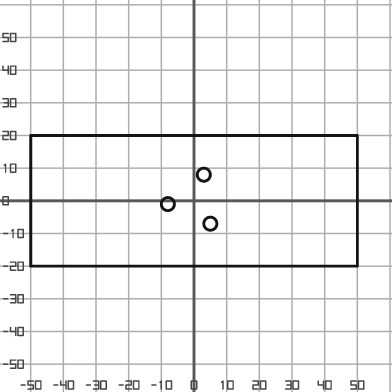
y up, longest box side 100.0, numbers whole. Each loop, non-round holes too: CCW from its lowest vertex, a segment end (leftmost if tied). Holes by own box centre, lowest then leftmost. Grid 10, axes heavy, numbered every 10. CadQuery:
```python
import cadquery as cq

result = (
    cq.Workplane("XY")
    .moveTo(-50.0, -20.0)
    .lineTo(50.0, -20.0)
    .lineTo(50.0, 20.0)
    .lineTo(-50.0, 20.0)
    .close()
    .moveTo(5.0, -7.0)
    .circle(2.0)
    .moveTo(-8.0, -1.0)
    .circle(2.0)
    .moveTo(3.0, 8.0)
    .circle(2.0)
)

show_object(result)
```